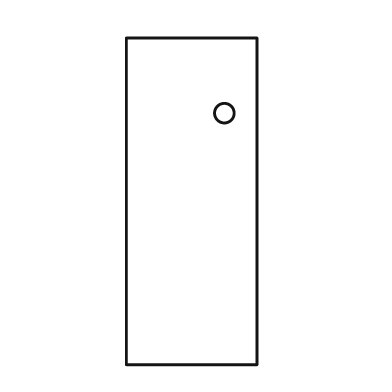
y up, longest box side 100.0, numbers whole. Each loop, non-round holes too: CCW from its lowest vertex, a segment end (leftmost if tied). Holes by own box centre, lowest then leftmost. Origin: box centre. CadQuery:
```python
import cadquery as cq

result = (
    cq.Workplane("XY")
    .moveTo(-20.0, -50.0)
    .lineTo(20.0, -50.0)
    .lineTo(20.0, 50.0)
    .lineTo(-20.0, 50.0)
    .close()
    .moveTo(10.0, 27.0)
    .circle(3.0)
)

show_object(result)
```